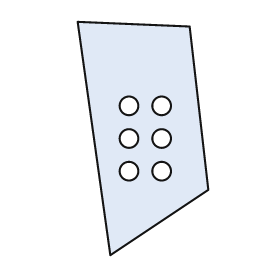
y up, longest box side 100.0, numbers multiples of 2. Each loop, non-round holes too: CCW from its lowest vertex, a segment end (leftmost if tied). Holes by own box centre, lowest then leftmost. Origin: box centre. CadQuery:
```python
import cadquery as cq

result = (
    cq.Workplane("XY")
    .moveTo(-14.0, -50.0)
    .lineTo(28.0, -22.0)
    .lineTo(20.0, 48.0)
    .lineTo(-28.0, 50.0)
    .close()
    .moveTo(-6.0, -14.0)
    .circle(4.0)
    .moveTo(8.0, -14.0)
    .circle(4.0)
    .moveTo(-6.0, 0.0)
    .circle(4.0)
    .moveTo(8.0, 0.0)
    .circle(4.0)
    .moveTo(-6.0, 14.0)
    .circle(4.0)
    .moveTo(8.0, 14.0)
    .circle(4.0)
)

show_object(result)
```